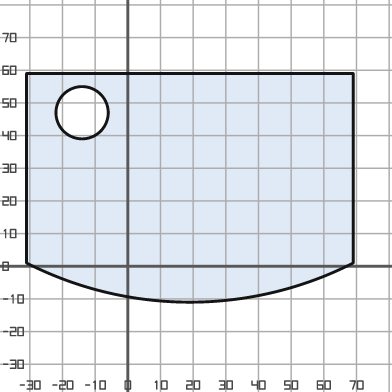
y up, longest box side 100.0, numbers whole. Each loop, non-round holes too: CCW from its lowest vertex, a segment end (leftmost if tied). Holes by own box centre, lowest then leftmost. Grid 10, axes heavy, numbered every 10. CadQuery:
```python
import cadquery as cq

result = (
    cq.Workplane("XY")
    .moveTo(-31.0, 1.0)
    .threePointArc((19.0, -11.0), (69.0, 1.0))
    .lineTo(69.0, 59.0)
    .lineTo(-31.0, 59.0)
    .close()
    .moveTo(-14.0, 47.0)
    .circle(8.0)
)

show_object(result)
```